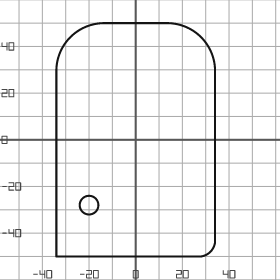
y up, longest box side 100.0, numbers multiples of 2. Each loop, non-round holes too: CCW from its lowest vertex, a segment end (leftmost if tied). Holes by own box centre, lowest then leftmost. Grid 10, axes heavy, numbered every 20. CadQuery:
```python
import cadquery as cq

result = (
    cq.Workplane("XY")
    .moveTo(-34.0, -50.0)
    .lineTo(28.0, -50.0)
    .threePointArc((32.0, -48.0), (34.0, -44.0))
    .lineTo(34.0, 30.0)
    .threePointArc((28.0, 44.0), (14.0, 50.0))
    .lineTo(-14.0, 50.0)
    .threePointArc((-28.0, 44.0), (-34.0, 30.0))
    .close()
    .moveTo(-20.0, -28.0)
    .circle(4.0)
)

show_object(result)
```